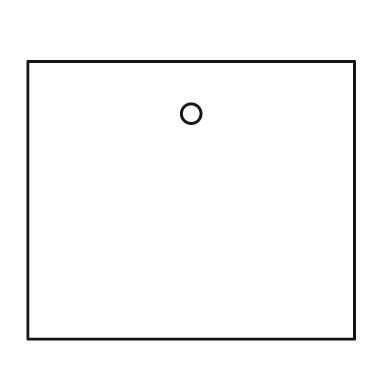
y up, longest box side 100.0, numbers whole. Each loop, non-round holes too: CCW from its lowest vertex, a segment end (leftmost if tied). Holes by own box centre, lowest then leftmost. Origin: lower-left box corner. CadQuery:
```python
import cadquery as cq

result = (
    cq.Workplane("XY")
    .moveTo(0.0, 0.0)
    .lineTo(100.0, 0.0)
    .lineTo(100.0, 85.0)
    .lineTo(0.0, 85.0)
    .close()
    .moveTo(50.0, 69.0)
    .circle(3.0)
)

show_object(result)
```